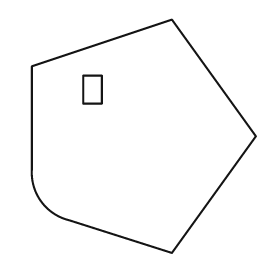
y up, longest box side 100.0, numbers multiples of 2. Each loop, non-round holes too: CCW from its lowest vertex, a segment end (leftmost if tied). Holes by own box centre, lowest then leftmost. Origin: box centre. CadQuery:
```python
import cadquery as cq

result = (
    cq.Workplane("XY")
    .moveTo(12.0, -50.0)
    .lineTo(48.0, 0.0)
    .lineTo(12.0, 50.0)
    .lineTo(-48.0, 30.0)
    .lineTo(-48.0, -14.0)
    .threePointArc((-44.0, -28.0), (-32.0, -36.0))
    .close()
    .moveTo(-26.0, 14.0)
    .lineTo(-18.0, 14.0)
    .lineTo(-18.0, 26.0)
    .lineTo(-26.0, 26.0)
    .close()
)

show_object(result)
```